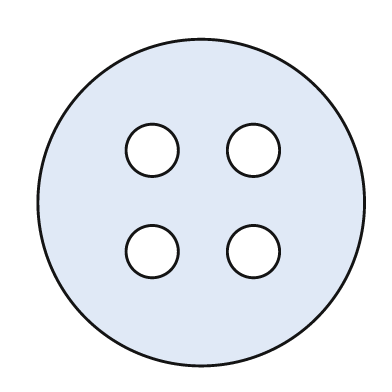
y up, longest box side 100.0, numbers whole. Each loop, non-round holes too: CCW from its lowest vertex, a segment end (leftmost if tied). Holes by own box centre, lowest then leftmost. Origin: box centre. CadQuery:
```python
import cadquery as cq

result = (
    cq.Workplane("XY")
    .moveTo(0.0, 0.0)
    .circle(50.0)
    .moveTo(-15.0, -15.0)
    .circle(8.0)
    .moveTo(16.0, -15.0)
    .circle(8.0)
    .moveTo(-15.0, 16.0)
    .circle(8.0)
    .moveTo(16.0, 16.0)
    .circle(8.0)
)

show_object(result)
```